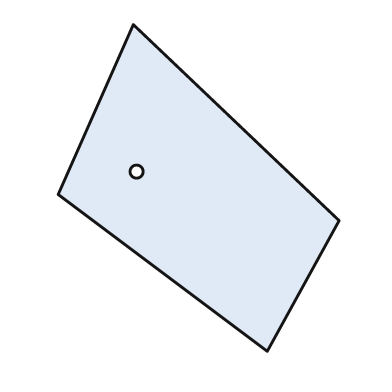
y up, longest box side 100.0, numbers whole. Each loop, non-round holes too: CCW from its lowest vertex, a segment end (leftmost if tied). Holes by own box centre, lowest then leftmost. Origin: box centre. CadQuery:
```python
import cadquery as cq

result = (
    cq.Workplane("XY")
    .moveTo(21.0, -50.0)
    .lineTo(43.0, -10.0)
    .lineTo(-20.0, 50.0)
    .lineTo(-43.0, -2.0)
    .close()
    .moveTo(-19.0, 5.0)
    .circle(2.0)
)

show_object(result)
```